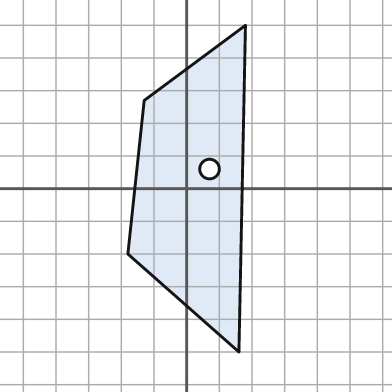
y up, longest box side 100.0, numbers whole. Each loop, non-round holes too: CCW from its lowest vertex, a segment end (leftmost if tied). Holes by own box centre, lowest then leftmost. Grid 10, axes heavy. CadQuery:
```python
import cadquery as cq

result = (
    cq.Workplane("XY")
    .moveTo(16.0, -50.0)
    .lineTo(18.0, 50.0)
    .lineTo(-13.0, 27.0)
    .lineTo(-18.0, -20.0)
    .close()
    .moveTo(7.0, 6.0)
    .circle(3.0)
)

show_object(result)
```